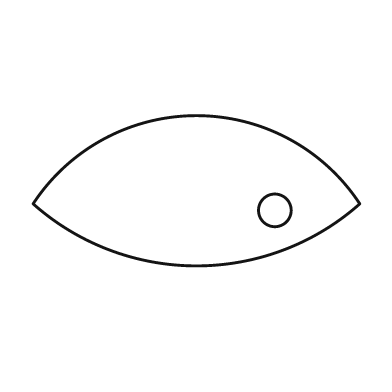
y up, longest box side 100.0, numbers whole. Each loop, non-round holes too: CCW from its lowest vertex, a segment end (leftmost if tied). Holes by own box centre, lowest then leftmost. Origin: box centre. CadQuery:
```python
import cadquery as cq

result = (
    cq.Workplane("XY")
    .moveTo(-50.0, -4.0)
    .threePointArc((0.0, -23.0), (50.0, -4.0))
    .threePointArc((0.0, 23.0), (-50.0, -4.0))
    .close()
    .moveTo(24.0, -6.0)
    .circle(5.0)
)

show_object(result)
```